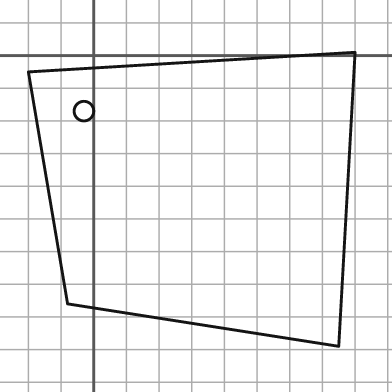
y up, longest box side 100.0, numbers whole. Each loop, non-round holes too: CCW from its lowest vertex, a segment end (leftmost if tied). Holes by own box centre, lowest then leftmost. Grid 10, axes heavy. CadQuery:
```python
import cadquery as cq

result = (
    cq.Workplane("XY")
    .moveTo(75.0, -89.0)
    .lineTo(80.0, 1.0)
    .lineTo(-20.0, -5.0)
    .lineTo(-8.0, -76.0)
    .close()
    .moveTo(-3.0, -17.0)
    .circle(3.0)
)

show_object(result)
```